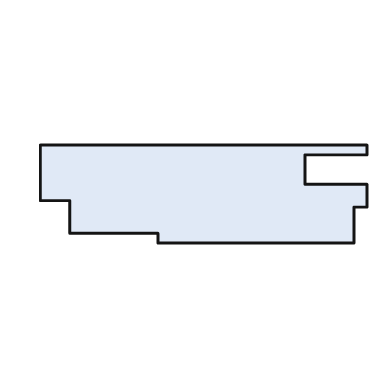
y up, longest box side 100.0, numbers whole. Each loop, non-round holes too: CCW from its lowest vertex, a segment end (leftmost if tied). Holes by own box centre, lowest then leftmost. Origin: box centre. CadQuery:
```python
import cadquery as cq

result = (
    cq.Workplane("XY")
    .moveTo(-14.0, -15.0)
    .lineTo(46.0, -15.0)
    .lineTo(46.0, -4.0)
    .lineTo(50.0, -4.0)
    .lineTo(50.0, 3.0)
    .lineTo(31.0, 3.0)
    .lineTo(31.0, 12.0)
    .lineTo(50.0, 12.0)
    .lineTo(50.0, 15.0)
    .lineTo(-50.0, 15.0)
    .lineTo(-50.0, -2.0)
    .lineTo(-41.0, -2.0)
    .lineTo(-41.0, -12.0)
    .lineTo(-14.0, -12.0)
    .close()
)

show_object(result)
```